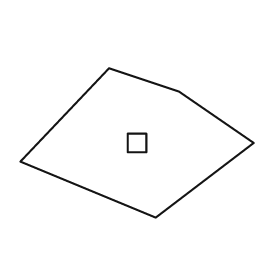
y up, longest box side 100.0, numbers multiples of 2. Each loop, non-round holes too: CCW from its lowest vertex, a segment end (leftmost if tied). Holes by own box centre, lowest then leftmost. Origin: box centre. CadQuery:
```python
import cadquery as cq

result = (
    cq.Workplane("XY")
    .moveTo(8.0, -32.0)
    .lineTo(50.0, 0.0)
    .lineTo(18.0, 22.0)
    .lineTo(-12.0, 32.0)
    .lineTo(-50.0, -8.0)
    .close()
    .moveTo(-4.0, -4.0)
    .lineTo(4.0, -4.0)
    .lineTo(4.0, 4.0)
    .lineTo(-4.0, 4.0)
    .close()
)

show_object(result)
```